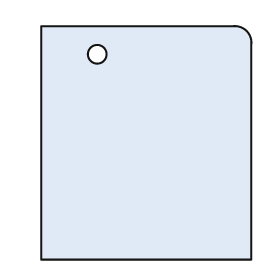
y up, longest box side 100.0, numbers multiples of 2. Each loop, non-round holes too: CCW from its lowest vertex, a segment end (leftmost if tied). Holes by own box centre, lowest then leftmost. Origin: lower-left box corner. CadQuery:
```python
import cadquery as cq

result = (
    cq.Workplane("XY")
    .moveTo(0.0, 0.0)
    .lineTo(90.0, 0.0)
    .lineTo(90.0, 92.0)
    .threePointArc((88.0, 98.0), (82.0, 100.0))
    .lineTo(0.0, 100.0)
    .close()
    .moveTo(24.0, 88.0)
    .circle(4.0)
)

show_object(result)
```